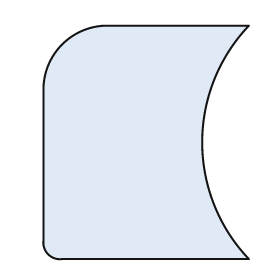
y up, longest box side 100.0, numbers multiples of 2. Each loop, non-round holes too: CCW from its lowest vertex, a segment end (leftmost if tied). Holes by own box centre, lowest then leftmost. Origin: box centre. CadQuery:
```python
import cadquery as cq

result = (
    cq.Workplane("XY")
    .moveTo(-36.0, -50.0)
    .lineTo(44.0, -50.0)
    .threePointArc((24.0, 0.0), (44.0, 50.0))
    .lineTo(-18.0, 50.0)
    .threePointArc((-36.0, 42.0), (-44.0, 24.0))
    .lineTo(-44.0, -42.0)
    .threePointArc((-42.0, -48.0), (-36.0, -50.0))
    .close()
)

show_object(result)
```